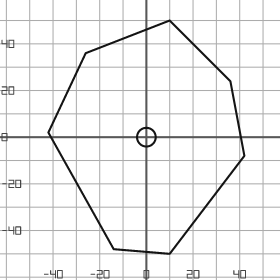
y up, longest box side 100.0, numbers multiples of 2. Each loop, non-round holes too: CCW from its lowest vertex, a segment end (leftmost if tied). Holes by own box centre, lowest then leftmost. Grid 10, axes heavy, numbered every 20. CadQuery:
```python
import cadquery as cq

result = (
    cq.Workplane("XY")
    .moveTo(10.0, -50.0)
    .lineTo(42.0, -8.0)
    .lineTo(36.0, 24.0)
    .lineTo(10.0, 50.0)
    .lineTo(-26.0, 36.0)
    .lineTo(-42.0, 2.0)
    .lineTo(-14.0, -48.0)
    .close()
    .moveTo(0.0, 0.0)
    .circle(4.0)
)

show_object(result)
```